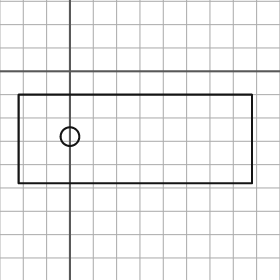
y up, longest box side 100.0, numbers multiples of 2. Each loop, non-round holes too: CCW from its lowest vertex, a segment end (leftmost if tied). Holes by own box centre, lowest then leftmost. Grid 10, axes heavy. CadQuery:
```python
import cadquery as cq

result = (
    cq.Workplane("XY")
    .moveTo(-22.0, -48.0)
    .lineTo(78.0, -48.0)
    .lineTo(78.0, -10.0)
    .lineTo(-22.0, -10.0)
    .close()
    .moveTo(0.0, -28.0)
    .circle(4.0)
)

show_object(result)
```